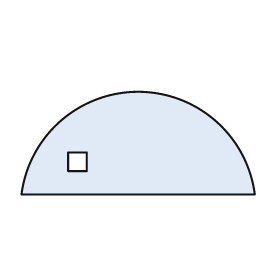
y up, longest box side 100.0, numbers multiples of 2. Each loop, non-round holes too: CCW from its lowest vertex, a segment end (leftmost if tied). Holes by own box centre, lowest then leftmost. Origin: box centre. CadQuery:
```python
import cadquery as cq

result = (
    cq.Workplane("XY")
    .moveTo(-50.0, -22.0)
    .lineTo(50.0, -22.0)
    .threePointArc((0.0, 22.0), (-50.0, -22.0))
    .close()
    .moveTo(-30.0, -12.0)
    .lineTo(-22.0, -12.0)
    .lineTo(-22.0, -4.0)
    .lineTo(-30.0, -4.0)
    .close()
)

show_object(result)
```